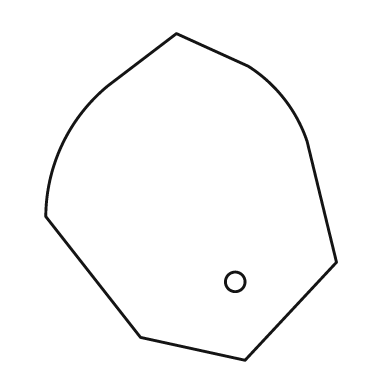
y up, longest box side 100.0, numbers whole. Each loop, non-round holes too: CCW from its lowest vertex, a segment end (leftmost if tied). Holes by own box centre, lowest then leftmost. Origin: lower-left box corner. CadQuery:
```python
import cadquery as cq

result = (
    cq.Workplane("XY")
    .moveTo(61.0, 0.0)
    .lineTo(89.0, 30.0)
    .lineTo(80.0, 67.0)
    .threePointArc((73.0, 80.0), (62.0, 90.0))
    .lineTo(40.0, 100.0)
    .lineTo(19.0, 84.0)
    .threePointArc((5.0, 66.0), (0.0, 44.0))
    .lineTo(29.0, 7.0)
    .close()
    .moveTo(58.0, 24.0)
    .circle(3.0)
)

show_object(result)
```